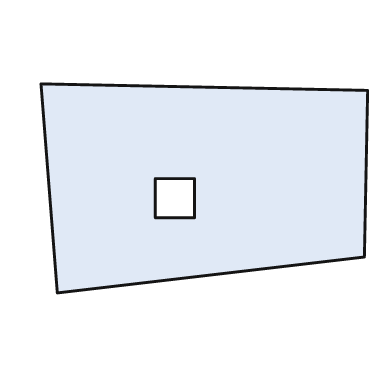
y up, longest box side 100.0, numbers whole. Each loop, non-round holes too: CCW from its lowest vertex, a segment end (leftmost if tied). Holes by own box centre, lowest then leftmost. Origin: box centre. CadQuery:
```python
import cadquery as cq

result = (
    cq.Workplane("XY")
    .moveTo(-45.0, -32.0)
    .lineTo(49.0, -21.0)
    .lineTo(50.0, 30.0)
    .lineTo(-50.0, 32.0)
    .close()
    .moveTo(-15.0, -9.0)
    .lineTo(-3.0, -9.0)
    .lineTo(-3.0, 3.0)
    .lineTo(-15.0, 3.0)
    .close()
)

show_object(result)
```